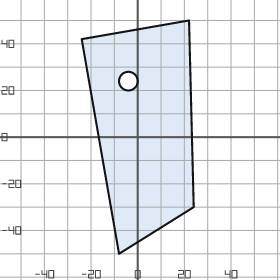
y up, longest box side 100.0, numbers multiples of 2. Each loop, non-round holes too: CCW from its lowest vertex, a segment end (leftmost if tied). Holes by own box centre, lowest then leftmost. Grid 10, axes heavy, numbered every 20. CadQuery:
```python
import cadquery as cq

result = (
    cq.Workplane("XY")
    .moveTo(-8.0, -50.0)
    .lineTo(24.0, -30.0)
    .lineTo(22.0, 50.0)
    .lineTo(-24.0, 42.0)
    .close()
    .moveTo(-4.0, 24.0)
    .circle(4.0)
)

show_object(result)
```